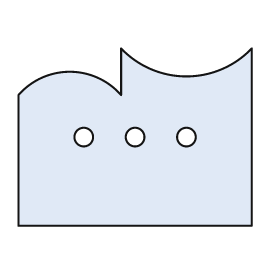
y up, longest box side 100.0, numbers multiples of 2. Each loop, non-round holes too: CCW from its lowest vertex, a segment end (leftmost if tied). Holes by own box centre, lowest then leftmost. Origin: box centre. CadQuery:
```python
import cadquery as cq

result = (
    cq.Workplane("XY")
    .moveTo(-50.0, -38.0)
    .lineTo(50.0, -38.0)
    .lineTo(50.0, 38.0)
    .threePointArc((22.0, 26.0), (-6.0, 38.0))
    .lineTo(-6.0, 18.0)
    .threePointArc((-28.0, 28.0), (-50.0, 18.0))
    .close()
    .moveTo(-22.0, 0.0)
    .circle(4.0)
    .moveTo(0.0, 0.0)
    .circle(4.0)
    .moveTo(22.0, 0.0)
    .circle(4.0)
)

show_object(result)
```